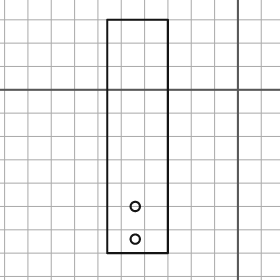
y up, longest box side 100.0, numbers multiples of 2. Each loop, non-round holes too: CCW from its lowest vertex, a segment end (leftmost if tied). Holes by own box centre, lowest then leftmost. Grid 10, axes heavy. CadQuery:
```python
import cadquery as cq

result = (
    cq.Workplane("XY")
    .moveTo(-56.0, -70.0)
    .lineTo(-30.0, -70.0)
    .lineTo(-30.0, 30.0)
    .lineTo(-56.0, 30.0)
    .close()
    .moveTo(-44.0, -64.0)
    .circle(2.0)
    .moveTo(-44.0, -50.0)
    .circle(2.0)
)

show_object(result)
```